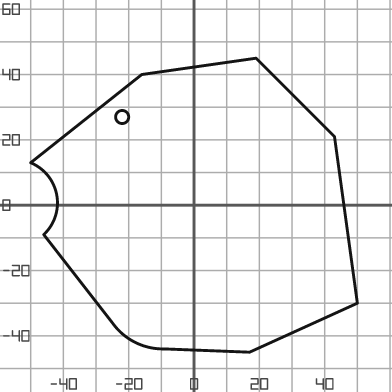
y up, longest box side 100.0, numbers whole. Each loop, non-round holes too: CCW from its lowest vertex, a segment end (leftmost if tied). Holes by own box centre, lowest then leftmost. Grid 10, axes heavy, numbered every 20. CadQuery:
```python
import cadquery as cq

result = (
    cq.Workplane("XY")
    .moveTo(17.0, -45.0)
    .lineTo(50.0, -30.0)
    .lineTo(43.0, 21.0)
    .lineTo(19.0, 45.0)
    .lineTo(-16.0, 40.0)
    .lineTo(-50.0, 13.0)
    .threePointArc((-42.0, 3.0), (-46.0, -9.0))
    .lineTo(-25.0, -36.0)
    .threePointArc((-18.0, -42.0), (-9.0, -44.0))
    .close()
    .moveTo(-22.0, 27.0)
    .circle(2.0)
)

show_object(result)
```